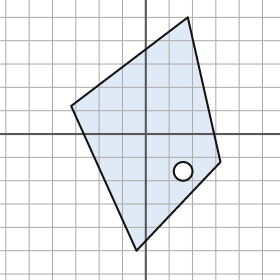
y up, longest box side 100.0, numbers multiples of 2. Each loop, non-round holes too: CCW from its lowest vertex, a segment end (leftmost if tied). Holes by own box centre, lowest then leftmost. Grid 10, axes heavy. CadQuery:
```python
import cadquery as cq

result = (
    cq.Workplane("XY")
    .moveTo(-4.0, -50.0)
    .lineTo(32.0, -12.0)
    .lineTo(18.0, 50.0)
    .lineTo(-32.0, 12.0)
    .close()
    .moveTo(16.0, -16.0)
    .circle(4.0)
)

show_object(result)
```